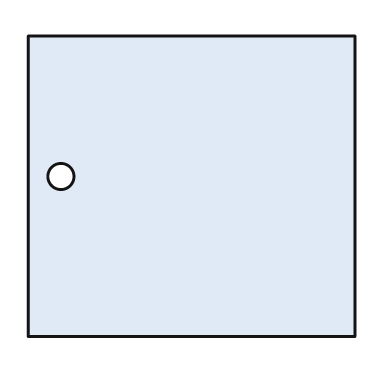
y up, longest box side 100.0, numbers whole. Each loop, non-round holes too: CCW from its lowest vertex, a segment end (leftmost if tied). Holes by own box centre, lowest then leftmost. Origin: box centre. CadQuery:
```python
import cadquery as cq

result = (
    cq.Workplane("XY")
    .moveTo(-50.0, -46.0)
    .lineTo(50.0, -46.0)
    .lineTo(50.0, 46.0)
    .lineTo(-50.0, 46.0)
    .close()
    .moveTo(-40.0, 3.0)
    .circle(4.0)
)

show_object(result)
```